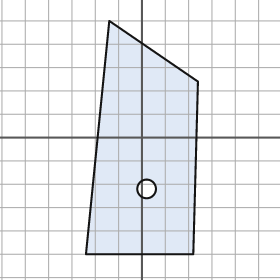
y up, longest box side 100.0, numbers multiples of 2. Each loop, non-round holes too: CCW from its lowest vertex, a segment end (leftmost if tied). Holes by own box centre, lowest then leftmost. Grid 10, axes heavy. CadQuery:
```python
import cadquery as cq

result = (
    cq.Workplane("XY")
    .moveTo(-24.0, -50.0)
    .lineTo(22.0, -50.0)
    .lineTo(24.0, 24.0)
    .lineTo(-14.0, 50.0)
    .close()
    .moveTo(2.0, -22.0)
    .circle(4.0)
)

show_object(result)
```